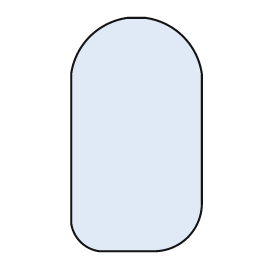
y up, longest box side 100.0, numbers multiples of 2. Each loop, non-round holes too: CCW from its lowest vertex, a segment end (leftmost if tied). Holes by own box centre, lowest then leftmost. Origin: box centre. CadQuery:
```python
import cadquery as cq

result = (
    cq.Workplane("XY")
    .moveTo(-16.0, -50.0)
    .lineTo(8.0, -50.0)
    .threePointArc((22.0, -44.0), (28.0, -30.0))
    .lineTo(28.0, 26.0)
    .threePointArc((20.0, 42.0), (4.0, 50.0))
    .lineTo(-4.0, 50.0)
    .threePointArc((-20.0, 42.0), (-28.0, 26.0))
    .lineTo(-28.0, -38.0)
    .threePointArc((-24.0, -46.0), (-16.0, -50.0))
    .close()
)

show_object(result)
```